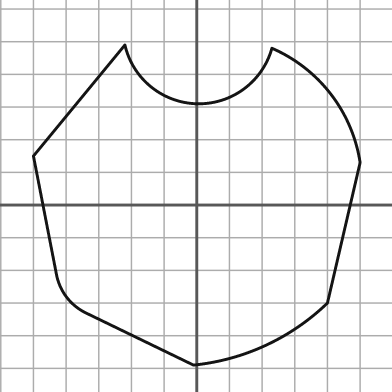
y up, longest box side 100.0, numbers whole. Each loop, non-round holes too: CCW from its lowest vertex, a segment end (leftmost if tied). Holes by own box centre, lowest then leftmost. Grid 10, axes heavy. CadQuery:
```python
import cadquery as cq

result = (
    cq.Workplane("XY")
    .moveTo(-1.0, -49.0)
    .threePointArc((21.0, -43.0), (40.0, -30.0))
    .lineTo(50.0, 13.0)
    .threePointArc((41.0, 34.0), (23.0, 48.0))
    .threePointArc((0.0, 31.0), (-22.0, 49.0))
    .lineTo(-50.0, 15.0)
    .lineTo(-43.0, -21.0)
    .threePointArc((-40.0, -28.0), (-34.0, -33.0))
    .close()
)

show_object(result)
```